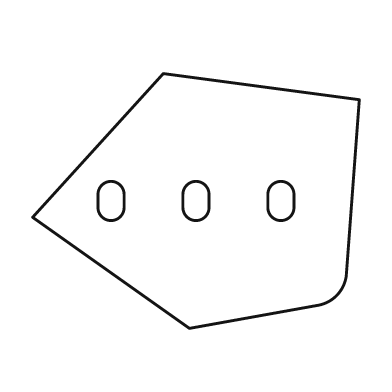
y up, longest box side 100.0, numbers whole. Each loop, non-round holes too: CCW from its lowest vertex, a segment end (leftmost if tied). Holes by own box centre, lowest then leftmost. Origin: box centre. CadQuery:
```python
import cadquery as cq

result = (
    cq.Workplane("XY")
    .moveTo(-2.0, -39.0)
    .lineTo(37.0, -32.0)
    .threePointArc((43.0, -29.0), (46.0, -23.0))
    .lineTo(50.0, 31.0)
    .lineTo(-10.0, 39.0)
    .lineTo(-50.0, -5.0)
    .close()
    .moveTo(-30.0, -2.0)
    .threePointArc((-26.0, -6.0), (-22.0, -2.0))
    .lineTo(-22.0, 2.0)
    .threePointArc((-26.0, 6.0), (-30.0, 2.0))
    .close()
    .moveTo(-4.0, -2.0)
    .threePointArc((0.0, -6.0), (4.0, -2.0))
    .lineTo(4.0, 2.0)
    .threePointArc((0.0, 6.0), (-4.0, 2.0))
    .close()
    .moveTo(22.0, -2.0)
    .threePointArc((26.0, -6.0), (30.0, -2.0))
    .lineTo(30.0, 2.0)
    .threePointArc((26.0, 6.0), (22.0, 2.0))
    .close()
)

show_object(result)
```